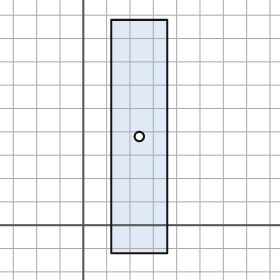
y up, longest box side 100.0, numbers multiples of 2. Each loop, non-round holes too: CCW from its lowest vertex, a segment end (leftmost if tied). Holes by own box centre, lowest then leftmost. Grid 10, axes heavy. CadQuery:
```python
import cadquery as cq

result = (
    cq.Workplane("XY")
    .moveTo(12.0, -12.0)
    .lineTo(36.0, -12.0)
    .lineTo(36.0, 88.0)
    .lineTo(12.0, 88.0)
    .close()
    .moveTo(24.0, 38.0)
    .circle(2.0)
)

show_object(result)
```